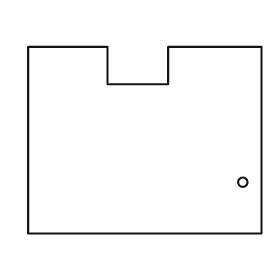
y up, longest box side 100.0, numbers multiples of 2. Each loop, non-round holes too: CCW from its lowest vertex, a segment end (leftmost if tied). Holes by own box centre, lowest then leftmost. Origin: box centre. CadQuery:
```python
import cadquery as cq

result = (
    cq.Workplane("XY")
    .moveTo(-50.0, -40.0)
    .lineTo(50.0, -40.0)
    .lineTo(50.0, 40.0)
    .lineTo(10.0, 40.0)
    .lineTo(10.0, 24.0)
    .lineTo(-16.0, 24.0)
    .lineTo(-16.0, 40.0)
    .lineTo(-50.0, 40.0)
    .close()
    .moveTo(42.0, -18.0)
    .circle(2.0)
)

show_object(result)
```